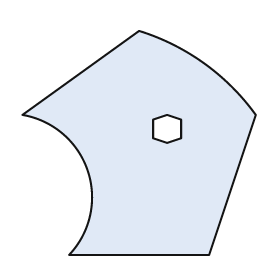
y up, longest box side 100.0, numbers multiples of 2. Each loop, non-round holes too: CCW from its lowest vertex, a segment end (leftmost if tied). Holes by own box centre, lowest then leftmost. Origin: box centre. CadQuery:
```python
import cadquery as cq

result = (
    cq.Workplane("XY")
    .moveTo(-30.0, -48.0)
    .lineTo(30.0, -48.0)
    .lineTo(50.0, 12.0)
    .threePointArc((28.0, 34.0), (0.0, 48.0))
    .lineTo(-50.0, 12.0)
    .threePointArc((-22.0, -12.0), (-30.0, -48.0))
    .close()
    .moveTo(12.0, 0.0)
    .lineTo(18.0, 2.0)
    .lineTo(18.0, 10.0)
    .lineTo(12.0, 12.0)
    .lineTo(6.0, 10.0)
    .lineTo(6.0, 2.0)
    .close()
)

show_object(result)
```